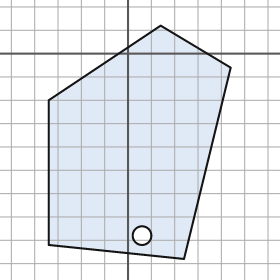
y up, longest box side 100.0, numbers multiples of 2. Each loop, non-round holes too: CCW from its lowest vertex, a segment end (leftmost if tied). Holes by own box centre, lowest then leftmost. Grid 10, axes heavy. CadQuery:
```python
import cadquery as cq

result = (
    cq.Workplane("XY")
    .moveTo(24.0, -88.0)
    .lineTo(44.0, -6.0)
    .lineTo(14.0, 12.0)
    .lineTo(-34.0, -20.0)
    .lineTo(-34.0, -82.0)
    .close()
    .moveTo(6.0, -78.0)
    .circle(4.0)
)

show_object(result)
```